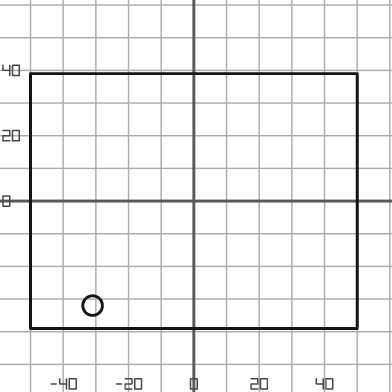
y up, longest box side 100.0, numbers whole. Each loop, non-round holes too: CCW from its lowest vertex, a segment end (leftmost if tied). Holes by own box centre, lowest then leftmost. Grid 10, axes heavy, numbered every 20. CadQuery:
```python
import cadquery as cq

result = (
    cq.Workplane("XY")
    .moveTo(-50.0, -39.0)
    .lineTo(50.0, -39.0)
    .lineTo(50.0, 39.0)
    .lineTo(-50.0, 39.0)
    .close()
    .moveTo(-31.0, -32.0)
    .circle(3.0)
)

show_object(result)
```